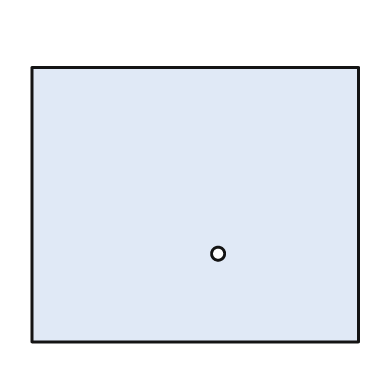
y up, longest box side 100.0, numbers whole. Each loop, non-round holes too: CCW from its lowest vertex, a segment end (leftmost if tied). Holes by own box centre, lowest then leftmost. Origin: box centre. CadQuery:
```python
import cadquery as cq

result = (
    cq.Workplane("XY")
    .moveTo(-50.0, -42.0)
    .lineTo(50.0, -42.0)
    .lineTo(50.0, 42.0)
    .lineTo(-50.0, 42.0)
    .close()
    .moveTo(7.0, -15.0)
    .circle(2.0)
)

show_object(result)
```